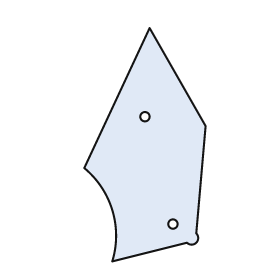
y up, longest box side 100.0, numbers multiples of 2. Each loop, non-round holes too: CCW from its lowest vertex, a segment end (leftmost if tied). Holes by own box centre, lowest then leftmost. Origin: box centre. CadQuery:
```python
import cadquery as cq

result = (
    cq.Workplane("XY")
    .moveTo(-14.0, -50.0)
    .lineTo(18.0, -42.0)
    .threePointArc((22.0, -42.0), (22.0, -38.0))
    .lineTo(26.0, 8.0)
    .lineTo(2.0, 50.0)
    .lineTo(-26.0, -10.0)
    .threePointArc((-14.0, -28.0), (-14.0, -50.0))
    .close()
    .moveTo(12.0, -34.0)
    .circle(2.0)
    .moveTo(0.0, 12.0)
    .circle(2.0)
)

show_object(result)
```